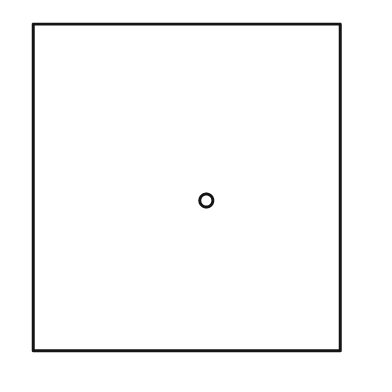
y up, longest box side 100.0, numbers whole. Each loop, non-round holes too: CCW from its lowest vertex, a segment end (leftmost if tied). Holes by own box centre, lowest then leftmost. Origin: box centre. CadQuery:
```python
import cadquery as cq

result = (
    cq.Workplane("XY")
    .moveTo(-47.0, -50.0)
    .lineTo(47.0, -50.0)
    .lineTo(47.0, 50.0)
    .lineTo(-47.0, 50.0)
    .close()
    .moveTo(6.0, -4.0)
    .circle(2.0)
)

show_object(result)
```